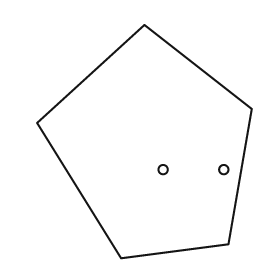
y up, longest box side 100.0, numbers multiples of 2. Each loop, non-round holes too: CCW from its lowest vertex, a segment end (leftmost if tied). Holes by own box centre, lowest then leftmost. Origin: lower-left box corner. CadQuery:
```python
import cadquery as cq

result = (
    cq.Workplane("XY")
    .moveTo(36.0, 0.0)
    .lineTo(82.0, 6.0)
    .lineTo(92.0, 64.0)
    .lineTo(46.0, 100.0)
    .lineTo(0.0, 58.0)
    .close()
    .moveTo(54.0, 38.0)
    .circle(2.0)
    .moveTo(80.0, 38.0)
    .circle(2.0)
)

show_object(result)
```